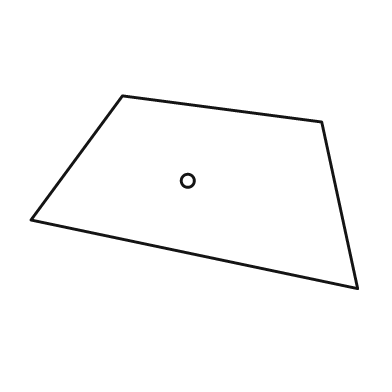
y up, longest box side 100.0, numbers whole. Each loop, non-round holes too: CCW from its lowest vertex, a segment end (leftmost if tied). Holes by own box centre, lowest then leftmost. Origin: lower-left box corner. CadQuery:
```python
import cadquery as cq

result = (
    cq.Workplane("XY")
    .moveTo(100.0, 0.0)
    .lineTo(89.0, 51.0)
    .lineTo(28.0, 59.0)
    .lineTo(0.0, 21.0)
    .close()
    .moveTo(48.0, 33.0)
    .circle(2.0)
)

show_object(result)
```